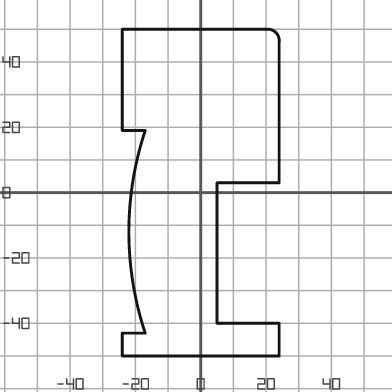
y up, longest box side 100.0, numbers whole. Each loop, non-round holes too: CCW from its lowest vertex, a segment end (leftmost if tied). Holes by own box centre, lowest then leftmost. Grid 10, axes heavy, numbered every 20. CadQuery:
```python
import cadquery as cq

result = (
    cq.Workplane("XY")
    .moveTo(-24.0, -50.0)
    .lineTo(24.0, -50.0)
    .lineTo(24.0, -40.0)
    .lineTo(5.0, -40.0)
    .lineTo(5.0, 3.0)
    .lineTo(24.0, 3.0)
    .lineTo(24.0, 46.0)
    .threePointArc((23.0, 49.0), (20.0, 50.0))
    .lineTo(-24.0, 50.0)
    .lineTo(-24.0, 19.0)
    .lineTo(-17.0, 19.0)
    .threePointArc((-22.0, -12.0), (-17.0, -43.0))
    .lineTo(-24.0, -43.0)
    .close()
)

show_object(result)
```